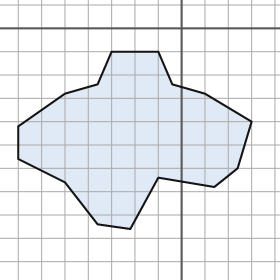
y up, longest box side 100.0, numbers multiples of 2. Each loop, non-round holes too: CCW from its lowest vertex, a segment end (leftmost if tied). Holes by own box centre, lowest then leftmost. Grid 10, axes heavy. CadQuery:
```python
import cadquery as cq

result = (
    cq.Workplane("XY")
    .moveTo(-22.0, -86.0)
    .lineTo(-10.0, -64.0)
    .lineTo(14.0, -68.0)
    .lineTo(24.0, -60.0)
    .lineTo(30.0, -40.0)
    .lineTo(10.0, -28.0)
    .lineTo(-4.0, -24.0)
    .lineTo(-10.0, -10.0)
    .lineTo(-30.0, -10.0)
    .lineTo(-36.0, -24.0)
    .lineTo(-50.0, -28.0)
    .lineTo(-70.0, -42.0)
    .lineTo(-70.0, -56.0)
    .lineTo(-50.0, -66.0)
    .lineTo(-36.0, -84.0)
    .close()
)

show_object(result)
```